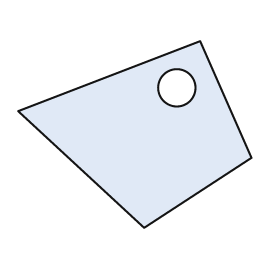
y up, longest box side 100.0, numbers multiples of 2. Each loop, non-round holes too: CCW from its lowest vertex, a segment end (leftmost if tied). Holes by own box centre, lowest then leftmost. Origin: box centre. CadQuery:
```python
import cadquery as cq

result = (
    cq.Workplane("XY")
    .moveTo(4.0, -40.0)
    .lineTo(50.0, -10.0)
    .lineTo(28.0, 40.0)
    .lineTo(-50.0, 10.0)
    .close()
    .moveTo(18.0, 20.0)
    .circle(8.0)
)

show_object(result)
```